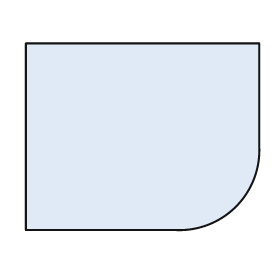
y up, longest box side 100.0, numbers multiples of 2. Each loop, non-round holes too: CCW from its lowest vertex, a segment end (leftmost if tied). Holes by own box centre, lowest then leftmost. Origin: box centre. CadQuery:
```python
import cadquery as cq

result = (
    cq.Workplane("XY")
    .moveTo(-50.0, -40.0)
    .lineTo(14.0, -40.0)
    .threePointArc((40.0, -30.0), (50.0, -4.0))
    .lineTo(50.0, 40.0)
    .lineTo(-50.0, 40.0)
    .close()
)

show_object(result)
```